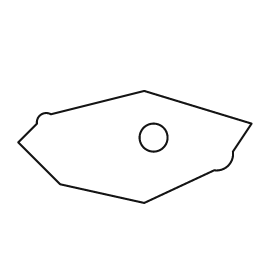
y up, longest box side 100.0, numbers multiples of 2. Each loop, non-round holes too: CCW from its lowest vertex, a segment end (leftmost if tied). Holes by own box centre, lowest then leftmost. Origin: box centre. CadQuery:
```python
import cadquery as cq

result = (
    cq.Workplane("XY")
    .moveTo(4.0, -24.0)
    .lineTo(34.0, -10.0)
    .threePointArc((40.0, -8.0), (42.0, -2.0))
    .lineTo(50.0, 10.0)
    .lineTo(4.0, 24.0)
    .lineTo(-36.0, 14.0)
    .threePointArc((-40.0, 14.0), (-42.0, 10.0))
    .lineTo(-50.0, 2.0)
    .lineTo(-32.0, -16.0)
    .close()
    .moveTo(8.0, 4.0)
    .circle(6.0)
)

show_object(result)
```